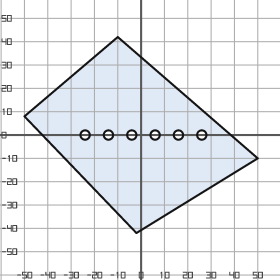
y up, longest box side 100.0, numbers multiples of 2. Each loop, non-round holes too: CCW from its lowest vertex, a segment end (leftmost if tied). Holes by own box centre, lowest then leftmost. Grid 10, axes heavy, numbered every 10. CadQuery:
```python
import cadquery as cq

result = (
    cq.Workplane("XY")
    .moveTo(-2.0, -42.0)
    .lineTo(50.0, -10.0)
    .lineTo(-10.0, 42.0)
    .lineTo(-50.0, 8.0)
    .close()
    .moveTo(-24.0, 0.0)
    .circle(2.0)
    .moveTo(-14.0, 0.0)
    .circle(2.0)
    .moveTo(-4.0, 0.0)
    .circle(2.0)
    .moveTo(6.0, 0.0)
    .circle(2.0)
    .moveTo(16.0, 0.0)
    .circle(2.0)
    .moveTo(26.0, 0.0)
    .circle(2.0)
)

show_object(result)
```